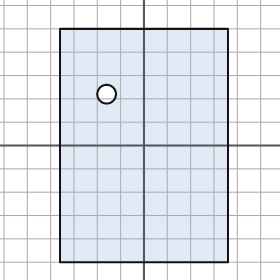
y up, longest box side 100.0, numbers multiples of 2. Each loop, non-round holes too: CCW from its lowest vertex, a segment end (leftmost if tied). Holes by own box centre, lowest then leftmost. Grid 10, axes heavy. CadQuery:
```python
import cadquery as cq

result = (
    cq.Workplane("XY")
    .moveTo(-36.0, -50.0)
    .lineTo(36.0, -50.0)
    .lineTo(36.0, 50.0)
    .lineTo(-36.0, 50.0)
    .close()
    .moveTo(-16.0, 22.0)
    .circle(4.0)
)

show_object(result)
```